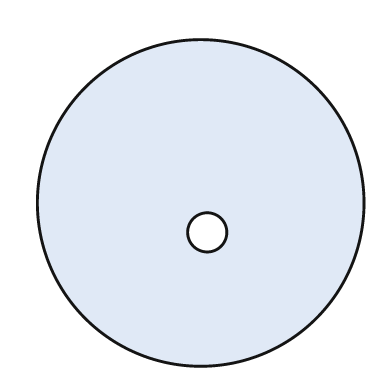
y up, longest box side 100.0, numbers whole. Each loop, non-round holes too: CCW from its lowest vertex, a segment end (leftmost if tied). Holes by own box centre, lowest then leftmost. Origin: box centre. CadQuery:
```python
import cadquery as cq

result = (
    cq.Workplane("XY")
    .moveTo(0.0, 0.0)
    .circle(50.0)
    .moveTo(2.0, -9.0)
    .circle(6.0)
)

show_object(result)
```